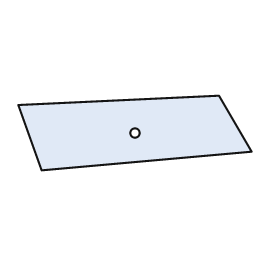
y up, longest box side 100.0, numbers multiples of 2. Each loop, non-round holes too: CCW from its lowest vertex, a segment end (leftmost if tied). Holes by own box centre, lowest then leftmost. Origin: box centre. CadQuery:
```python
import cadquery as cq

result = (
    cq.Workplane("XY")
    .moveTo(-40.0, -16.0)
    .lineTo(50.0, -8.0)
    .lineTo(36.0, 16.0)
    .lineTo(-50.0, 12.0)
    .close()
    .moveTo(0.0, 0.0)
    .circle(2.0)
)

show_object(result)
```